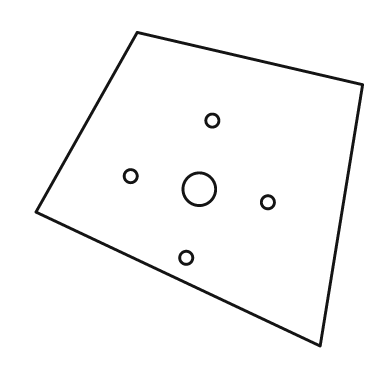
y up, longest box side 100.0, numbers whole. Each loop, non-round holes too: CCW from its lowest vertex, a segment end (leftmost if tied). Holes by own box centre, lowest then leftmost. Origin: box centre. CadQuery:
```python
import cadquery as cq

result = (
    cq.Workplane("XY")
    .moveTo(37.0, -48.0)
    .lineTo(50.0, 32.0)
    .lineTo(-19.0, 48.0)
    .lineTo(-50.0, -7.0)
    .close()
    .moveTo(-4.0, -21.0)
    .circle(2.0)
    .moveTo(21.0, -4.0)
    .circle(2.0)
    .moveTo(0.0, 0.0)
    .circle(5.0)
    .moveTo(-21.0, 4.0)
    .circle(2.0)
    .moveTo(4.0, 21.0)
    .circle(2.0)
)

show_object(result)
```